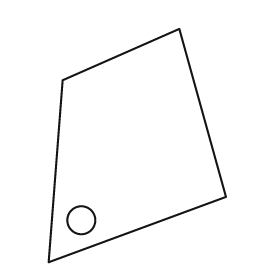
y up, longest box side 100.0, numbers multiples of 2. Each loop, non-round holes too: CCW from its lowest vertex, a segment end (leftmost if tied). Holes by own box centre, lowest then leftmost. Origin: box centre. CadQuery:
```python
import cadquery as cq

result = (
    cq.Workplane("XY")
    .moveTo(-38.0, -50.0)
    .lineTo(38.0, -22.0)
    .lineTo(18.0, 50.0)
    .lineTo(-32.0, 28.0)
    .close()
    .moveTo(-24.0, -32.0)
    .circle(6.0)
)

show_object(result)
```